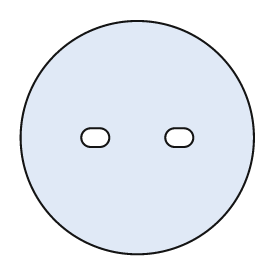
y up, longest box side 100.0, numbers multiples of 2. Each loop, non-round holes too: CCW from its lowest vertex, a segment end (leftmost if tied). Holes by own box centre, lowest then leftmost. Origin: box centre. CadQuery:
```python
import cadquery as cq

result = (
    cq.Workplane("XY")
    .moveTo(0.0, 0.0)
    .circle(50.0)
    .moveTo(-20.0, -4.0)
    .lineTo(-16.0, -4.0)
    .threePointArc((-12.0, 0.0), (-16.0, 4.0))
    .lineTo(-20.0, 4.0)
    .threePointArc((-24.0, 0.0), (-20.0, -4.0))
    .close()
    .moveTo(16.0, -4.0)
    .lineTo(20.0, -4.0)
    .threePointArc((24.0, 0.0), (20.0, 4.0))
    .lineTo(16.0, 4.0)
    .threePointArc((12.0, 0.0), (16.0, -4.0))
    .close()
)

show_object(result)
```